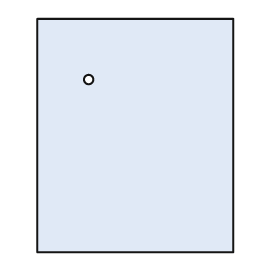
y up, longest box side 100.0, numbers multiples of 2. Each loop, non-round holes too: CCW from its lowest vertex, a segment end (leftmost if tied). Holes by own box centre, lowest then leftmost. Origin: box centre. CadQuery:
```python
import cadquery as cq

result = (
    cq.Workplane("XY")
    .moveTo(-42.0, -50.0)
    .lineTo(42.0, -50.0)
    .lineTo(42.0, 50.0)
    .lineTo(-42.0, 50.0)
    .close()
    .moveTo(-20.0, 24.0)
    .circle(2.0)
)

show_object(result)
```